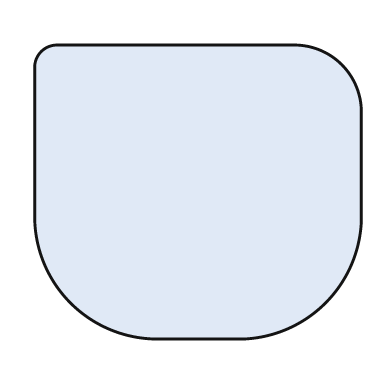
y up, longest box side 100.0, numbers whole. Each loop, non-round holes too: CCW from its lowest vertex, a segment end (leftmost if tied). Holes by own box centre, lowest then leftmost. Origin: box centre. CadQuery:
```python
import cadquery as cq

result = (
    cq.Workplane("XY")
    .moveTo(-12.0, -45.0)
    .lineTo(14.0, -45.0)
    .threePointArc((39.0, -34.0), (50.0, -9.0))
    .lineTo(50.0, 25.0)
    .threePointArc((44.0, 39.0), (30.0, 45.0))
    .lineTo(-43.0, 45.0)
    .threePointArc((-48.0, 43.0), (-50.0, 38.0))
    .lineTo(-50.0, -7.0)
    .threePointArc((-39.0, -34.0), (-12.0, -45.0))
    .close()
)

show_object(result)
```